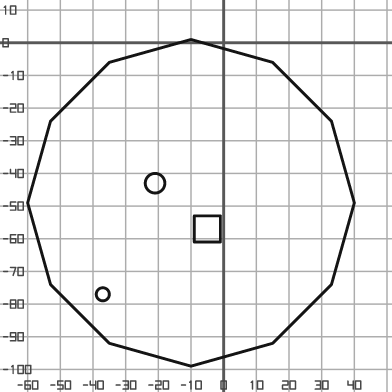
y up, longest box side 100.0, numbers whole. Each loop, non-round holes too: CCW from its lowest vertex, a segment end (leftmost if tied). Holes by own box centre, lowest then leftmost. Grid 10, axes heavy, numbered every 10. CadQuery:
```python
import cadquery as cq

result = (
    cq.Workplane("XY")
    .moveTo(-10.0, -99.0)
    .lineTo(15.0, -92.0)
    .lineTo(33.0, -74.0)
    .lineTo(40.0, -49.0)
    .lineTo(33.0, -24.0)
    .lineTo(15.0, -6.0)
    .lineTo(-10.0, 1.0)
    .lineTo(-35.0, -6.0)
    .lineTo(-53.0, -24.0)
    .lineTo(-60.0, -49.0)
    .lineTo(-53.0, -74.0)
    .lineTo(-35.0, -92.0)
    .close()
    .moveTo(-37.0, -77.0)
    .circle(2.0)
    .moveTo(-9.0, -61.0)
    .lineTo(-1.0, -61.0)
    .lineTo(-1.0, -53.0)
    .lineTo(-9.0, -53.0)
    .close()
    .moveTo(-21.0, -43.0)
    .circle(3.0)
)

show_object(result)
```